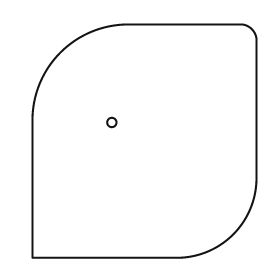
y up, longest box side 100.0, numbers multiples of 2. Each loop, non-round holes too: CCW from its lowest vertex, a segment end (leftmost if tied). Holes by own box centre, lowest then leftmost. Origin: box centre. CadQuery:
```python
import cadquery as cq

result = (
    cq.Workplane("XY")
    .moveTo(-48.0, -50.0)
    .lineTo(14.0, -50.0)
    .threePointArc((38.0, -40.0), (48.0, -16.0))
    .lineTo(48.0, 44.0)
    .threePointArc((46.0, 48.0), (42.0, 50.0))
    .lineTo(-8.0, 50.0)
    .threePointArc((-36.0, 38.0), (-48.0, 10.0))
    .close()
    .moveTo(-14.0, 8.0)
    .circle(2.0)
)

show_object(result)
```